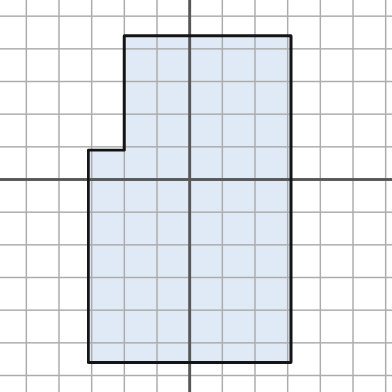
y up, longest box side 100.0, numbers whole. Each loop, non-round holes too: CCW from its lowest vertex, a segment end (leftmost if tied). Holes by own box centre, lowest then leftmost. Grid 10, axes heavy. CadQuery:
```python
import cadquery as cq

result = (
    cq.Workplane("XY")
    .moveTo(-31.0, -56.0)
    .lineTo(31.0, -56.0)
    .lineTo(31.0, 44.0)
    .lineTo(-20.0, 44.0)
    .lineTo(-20.0, 9.0)
    .lineTo(-31.0, 9.0)
    .close()
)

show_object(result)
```